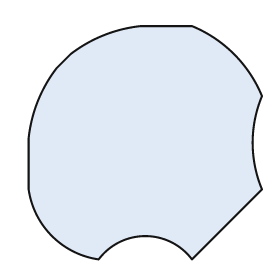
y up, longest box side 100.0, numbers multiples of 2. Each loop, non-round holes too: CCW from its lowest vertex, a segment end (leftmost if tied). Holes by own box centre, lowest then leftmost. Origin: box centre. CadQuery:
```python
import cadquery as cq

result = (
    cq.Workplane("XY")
    .moveTo(-20.0, -50.0)
    .threePointArc((0.0, -40.0), (20.0, -50.0))
    .lineTo(50.0, -20.0)
    .threePointArc((46.0, 0.0), (50.0, 20.0))
    .threePointArc((38.0, 38.0), (20.0, 50.0))
    .lineTo(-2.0, 50.0)
    .threePointArc((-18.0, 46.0), (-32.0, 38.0))
    .lineTo(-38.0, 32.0)
    .threePointArc((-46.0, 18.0), (-50.0, 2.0))
    .lineTo(-50.0, -20.0)
    .threePointArc((-40.0, -40.0), (-20.0, -50.0))
    .close()
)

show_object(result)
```